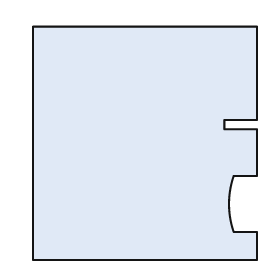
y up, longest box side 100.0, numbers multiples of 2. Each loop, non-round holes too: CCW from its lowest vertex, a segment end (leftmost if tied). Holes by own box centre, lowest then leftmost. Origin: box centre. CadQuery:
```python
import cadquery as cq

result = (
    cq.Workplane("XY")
    .moveTo(-48.0, -50.0)
    .lineTo(48.0, -50.0)
    .lineTo(48.0, -38.0)
    .lineTo(38.0, -38.0)
    .threePointArc((36.0, -26.0), (38.0, -14.0))
    .lineTo(48.0, -14.0)
    .lineTo(48.0, 6.0)
    .lineTo(34.0, 6.0)
    .lineTo(34.0, 10.0)
    .lineTo(48.0, 10.0)
    .lineTo(48.0, 50.0)
    .lineTo(-48.0, 50.0)
    .close()
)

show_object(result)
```